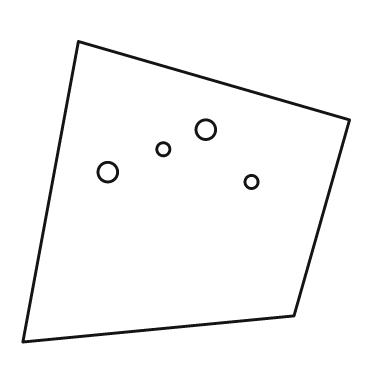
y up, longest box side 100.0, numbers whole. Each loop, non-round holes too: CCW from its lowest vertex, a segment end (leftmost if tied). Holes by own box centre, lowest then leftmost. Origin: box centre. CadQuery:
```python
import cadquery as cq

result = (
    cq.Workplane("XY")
    .moveTo(-50.0, -46.0)
    .lineTo(33.0, -38.0)
    .lineTo(50.0, 22.0)
    .lineTo(-33.0, 46.0)
    .close()
    .moveTo(20.0, 3.0)
    .circle(2.0)
    .moveTo(-24.0, 6.0)
    .circle(3.0)
    .moveTo(-7.0, 13.0)
    .circle(2.0)
    .moveTo(6.0, 19.0)
    .circle(3.0)
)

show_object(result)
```